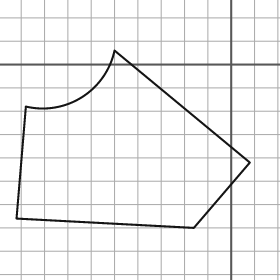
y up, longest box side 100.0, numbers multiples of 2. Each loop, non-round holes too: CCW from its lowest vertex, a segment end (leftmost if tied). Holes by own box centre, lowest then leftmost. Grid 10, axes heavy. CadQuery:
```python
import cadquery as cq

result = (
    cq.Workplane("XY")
    .moveTo(-16.0, -70.0)
    .lineTo(8.0, -42.0)
    .lineTo(-50.0, 6.0)
    .threePointArc((-64.0, -14.0), (-88.0, -18.0))
    .lineTo(-92.0, -66.0)
    .close()
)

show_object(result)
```